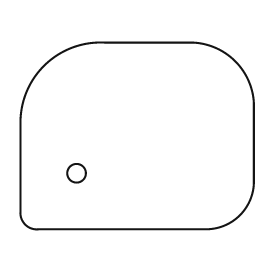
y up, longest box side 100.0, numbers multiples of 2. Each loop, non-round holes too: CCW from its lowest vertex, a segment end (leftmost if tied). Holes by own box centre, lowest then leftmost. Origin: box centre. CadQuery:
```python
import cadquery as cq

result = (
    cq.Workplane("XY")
    .moveTo(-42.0, -40.0)
    .lineTo(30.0, -40.0)
    .threePointArc((44.0, -34.0), (50.0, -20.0))
    .lineTo(50.0, 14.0)
    .threePointArc((42.0, 32.0), (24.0, 40.0))
    .lineTo(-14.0, 40.0)
    .threePointArc((-40.0, 30.0), (-50.0, 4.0))
    .lineTo(-50.0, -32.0)
    .threePointArc((-48.0, -38.0), (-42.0, -40.0))
    .close()
    .moveTo(-26.0, -16.0)
    .circle(4.0)
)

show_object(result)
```